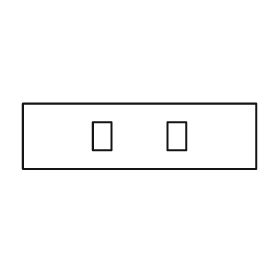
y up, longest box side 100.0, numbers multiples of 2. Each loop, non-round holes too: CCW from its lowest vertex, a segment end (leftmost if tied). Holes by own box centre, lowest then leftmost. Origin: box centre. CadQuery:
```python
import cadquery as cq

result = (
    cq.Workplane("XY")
    .moveTo(-50.0, -14.0)
    .lineTo(50.0, -14.0)
    .lineTo(50.0, 14.0)
    .lineTo(-50.0, 14.0)
    .close()
    .moveTo(-20.0, -6.0)
    .lineTo(-12.0, -6.0)
    .lineTo(-12.0, 6.0)
    .lineTo(-20.0, 6.0)
    .close()
    .moveTo(12.0, -6.0)
    .lineTo(20.0, -6.0)
    .lineTo(20.0, 6.0)
    .lineTo(12.0, 6.0)
    .close()
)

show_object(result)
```